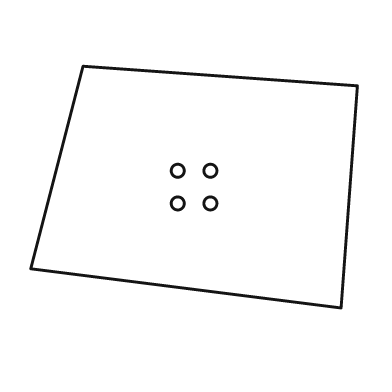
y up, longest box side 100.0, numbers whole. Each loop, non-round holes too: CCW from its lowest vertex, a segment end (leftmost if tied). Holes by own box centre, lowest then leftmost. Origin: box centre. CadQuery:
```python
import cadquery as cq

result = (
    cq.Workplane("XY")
    .moveTo(45.0, -37.0)
    .lineTo(50.0, 31.0)
    .lineTo(-34.0, 37.0)
    .lineTo(-50.0, -25.0)
    .close()
    .moveTo(-5.0, -5.0)
    .circle(2.0)
    .moveTo(5.0, -5.0)
    .circle(2.0)
    .moveTo(-5.0, 5.0)
    .circle(2.0)
    .moveTo(5.0, 5.0)
    .circle(2.0)
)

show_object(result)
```